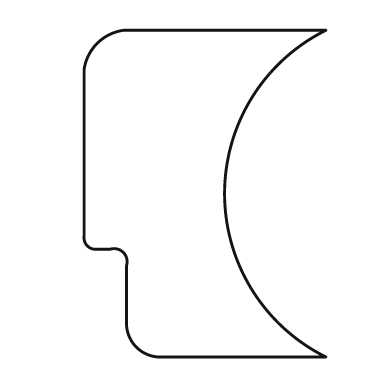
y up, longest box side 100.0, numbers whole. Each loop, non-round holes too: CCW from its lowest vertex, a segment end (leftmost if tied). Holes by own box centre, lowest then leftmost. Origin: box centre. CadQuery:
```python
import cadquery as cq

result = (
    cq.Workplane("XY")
    .moveTo(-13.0, -50.0)
    .lineTo(37.0, -50.0)
    .threePointArc((6.0, 0.0), (37.0, 50.0))
    .lineTo(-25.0, 50.0)
    .threePointArc((-33.0, 46.0), (-37.0, 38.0))
    .lineTo(-37.0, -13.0)
    .threePointArc((-36.0, -16.0), (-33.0, -17.0))
    .lineTo(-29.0, -17.0)
    .threePointArc((-25.0, -18.0), (-24.0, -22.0))
    .lineTo(-24.0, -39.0)
    .threePointArc((-21.0, -47.0), (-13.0, -50.0))
    .close()
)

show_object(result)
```